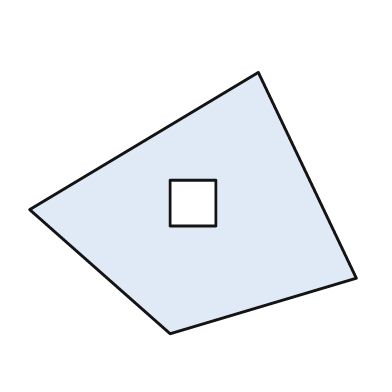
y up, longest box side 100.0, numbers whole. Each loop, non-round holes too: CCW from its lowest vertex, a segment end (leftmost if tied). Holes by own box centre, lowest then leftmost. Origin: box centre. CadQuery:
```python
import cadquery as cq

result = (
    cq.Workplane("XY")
    .moveTo(-7.0, -40.0)
    .lineTo(50.0, -23.0)
    .lineTo(20.0, 40.0)
    .lineTo(-50.0, -2.0)
    .close()
    .moveTo(-7.0, -7.0)
    .lineTo(7.0, -7.0)
    .lineTo(7.0, 7.0)
    .lineTo(-7.0, 7.0)
    .close()
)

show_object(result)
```